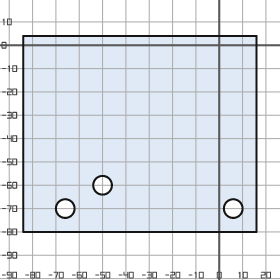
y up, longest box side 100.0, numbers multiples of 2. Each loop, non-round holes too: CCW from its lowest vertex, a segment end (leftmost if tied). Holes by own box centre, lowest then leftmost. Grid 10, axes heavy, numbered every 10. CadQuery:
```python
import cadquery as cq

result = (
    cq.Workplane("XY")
    .moveTo(-84.0, -80.0)
    .lineTo(16.0, -80.0)
    .lineTo(16.0, 4.0)
    .lineTo(-84.0, 4.0)
    .close()
    .moveTo(-66.0, -70.0)
    .circle(4.0)
    .moveTo(6.0, -70.0)
    .circle(4.0)
    .moveTo(-50.0, -60.0)
    .circle(4.0)
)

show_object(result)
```